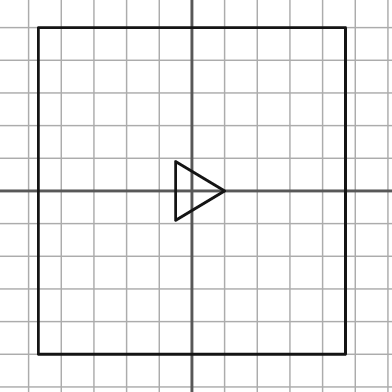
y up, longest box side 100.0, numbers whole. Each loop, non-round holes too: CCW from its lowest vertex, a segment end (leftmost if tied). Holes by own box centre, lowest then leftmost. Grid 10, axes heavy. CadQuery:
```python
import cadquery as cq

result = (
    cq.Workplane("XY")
    .moveTo(-47.0, -50.0)
    .lineTo(47.0, -50.0)
    .lineTo(47.0, 50.0)
    .lineTo(-47.0, 50.0)
    .close()
    .moveTo(-5.0, -9.0)
    .lineTo(10.0, 0.0)
    .lineTo(-5.0, 9.0)
    .close()
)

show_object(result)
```